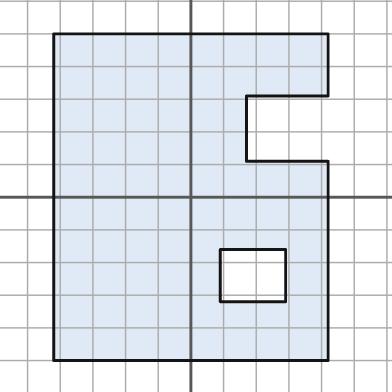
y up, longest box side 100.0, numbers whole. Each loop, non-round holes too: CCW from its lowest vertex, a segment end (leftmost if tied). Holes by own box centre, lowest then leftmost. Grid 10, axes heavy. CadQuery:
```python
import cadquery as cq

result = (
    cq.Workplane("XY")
    .moveTo(-42.0, -50.0)
    .lineTo(42.0, -50.0)
    .lineTo(42.0, 11.0)
    .lineTo(17.0, 11.0)
    .lineTo(17.0, 31.0)
    .lineTo(42.0, 31.0)
    .lineTo(42.0, 50.0)
    .lineTo(-42.0, 50.0)
    .close()
    .moveTo(9.0, -32.0)
    .lineTo(29.0, -32.0)
    .lineTo(29.0, -16.0)
    .lineTo(9.0, -16.0)
    .close()
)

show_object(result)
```